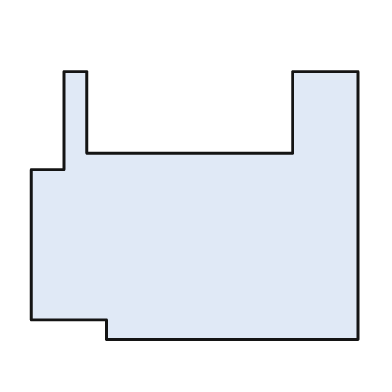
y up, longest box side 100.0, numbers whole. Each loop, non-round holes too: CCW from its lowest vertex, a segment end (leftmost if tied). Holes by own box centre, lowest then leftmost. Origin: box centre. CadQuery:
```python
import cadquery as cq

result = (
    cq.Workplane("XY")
    .moveTo(-27.0, -41.0)
    .lineTo(50.0, -41.0)
    .lineTo(50.0, 41.0)
    .lineTo(30.0, 41.0)
    .lineTo(30.0, 16.0)
    .lineTo(-33.0, 16.0)
    .lineTo(-33.0, 41.0)
    .lineTo(-40.0, 41.0)
    .lineTo(-40.0, 11.0)
    .lineTo(-50.0, 11.0)
    .lineTo(-50.0, -35.0)
    .lineTo(-27.0, -35.0)
    .close()
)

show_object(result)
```